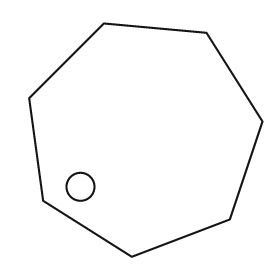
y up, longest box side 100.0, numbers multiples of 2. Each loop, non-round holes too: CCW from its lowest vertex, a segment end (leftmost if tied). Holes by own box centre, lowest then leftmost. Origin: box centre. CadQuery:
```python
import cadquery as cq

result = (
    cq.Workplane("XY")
    .moveTo(-6.0, -50.0)
    .lineTo(36.0, -34.0)
    .lineTo(50.0, 8.0)
    .lineTo(26.0, 46.0)
    .lineTo(-18.0, 50.0)
    .lineTo(-50.0, 18.0)
    .lineTo(-44.0, -26.0)
    .close()
    .moveTo(-28.0, -20.0)
    .circle(6.0)
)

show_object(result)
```